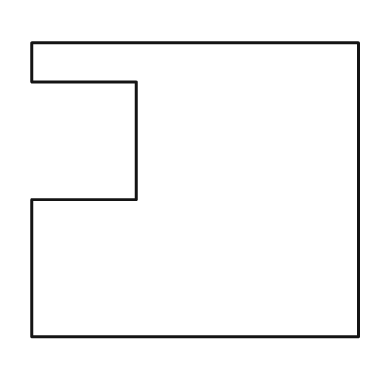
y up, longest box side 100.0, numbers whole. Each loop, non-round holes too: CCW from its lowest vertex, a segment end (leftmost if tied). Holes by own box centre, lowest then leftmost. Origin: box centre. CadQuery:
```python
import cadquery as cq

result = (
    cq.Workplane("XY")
    .moveTo(-50.0, -45.0)
    .lineTo(50.0, -45.0)
    .lineTo(50.0, 45.0)
    .lineTo(-50.0, 45.0)
    .lineTo(-50.0, 33.0)
    .lineTo(-18.0, 33.0)
    .lineTo(-18.0, -3.0)
    .lineTo(-50.0, -3.0)
    .close()
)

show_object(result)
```